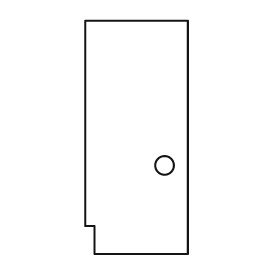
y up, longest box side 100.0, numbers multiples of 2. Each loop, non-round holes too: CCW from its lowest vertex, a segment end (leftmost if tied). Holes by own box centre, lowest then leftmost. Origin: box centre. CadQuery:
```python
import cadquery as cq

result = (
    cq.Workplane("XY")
    .moveTo(-18.0, -50.0)
    .lineTo(22.0, -50.0)
    .lineTo(22.0, 50.0)
    .lineTo(-22.0, 50.0)
    .lineTo(-22.0, -38.0)
    .lineTo(-18.0, -38.0)
    .close()
    .moveTo(12.0, -12.0)
    .circle(4.0)
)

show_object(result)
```